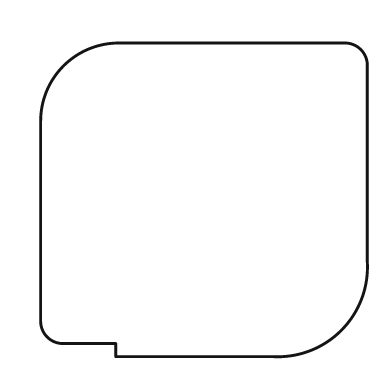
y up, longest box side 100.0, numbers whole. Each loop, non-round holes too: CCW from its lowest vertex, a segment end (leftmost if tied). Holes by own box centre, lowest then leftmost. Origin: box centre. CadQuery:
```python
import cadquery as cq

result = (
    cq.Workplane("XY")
    .moveTo(-27.0, -48.0)
    .lineTo(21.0, -48.0)
    .threePointArc((42.0, -40.0), (50.0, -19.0))
    .lineTo(50.0, 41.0)
    .threePointArc((48.0, 46.0), (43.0, 48.0))
    .lineTo(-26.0, 48.0)
    .threePointArc((-43.0, 41.0), (-50.0, 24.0))
    .lineTo(-50.0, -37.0)
    .threePointArc((-48.0, -42.0), (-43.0, -44.0))
    .lineTo(-27.0, -44.0)
    .close()
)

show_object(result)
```